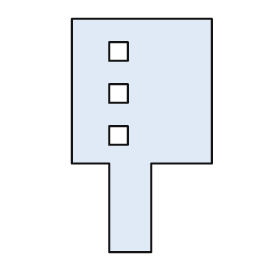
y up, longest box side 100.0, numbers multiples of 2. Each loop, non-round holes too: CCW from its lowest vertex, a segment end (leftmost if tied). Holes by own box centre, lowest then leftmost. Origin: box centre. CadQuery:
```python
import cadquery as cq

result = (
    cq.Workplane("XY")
    .moveTo(-14.0, -50.0)
    .lineTo(4.0, -50.0)
    .lineTo(4.0, -12.0)
    .lineTo(30.0, -12.0)
    .lineTo(30.0, 50.0)
    .lineTo(-30.0, 50.0)
    .lineTo(-30.0, -12.0)
    .lineTo(-14.0, -12.0)
    .close()
    .moveTo(-14.0, -4.0)
    .lineTo(-6.0, -4.0)
    .lineTo(-6.0, 4.0)
    .lineTo(-14.0, 4.0)
    .close()
    .moveTo(-14.0, 14.0)
    .lineTo(-6.0, 14.0)
    .lineTo(-6.0, 22.0)
    .lineTo(-14.0, 22.0)
    .close()
    .moveTo(-14.0, 32.0)
    .lineTo(-6.0, 32.0)
    .lineTo(-6.0, 40.0)
    .lineTo(-14.0, 40.0)
    .close()
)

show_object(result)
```